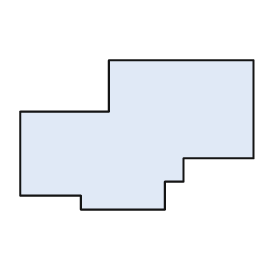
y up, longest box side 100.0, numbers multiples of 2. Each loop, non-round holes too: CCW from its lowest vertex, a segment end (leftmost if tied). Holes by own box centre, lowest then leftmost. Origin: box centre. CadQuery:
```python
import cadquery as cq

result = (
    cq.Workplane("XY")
    .moveTo(-24.0, -32.0)
    .lineTo(12.0, -32.0)
    .lineTo(12.0, -20.0)
    .lineTo(20.0, -20.0)
    .lineTo(20.0, -10.0)
    .lineTo(50.0, -10.0)
    .lineTo(50.0, 32.0)
    .lineTo(-12.0, 32.0)
    .lineTo(-12.0, 10.0)
    .lineTo(-50.0, 10.0)
    .lineTo(-50.0, -26.0)
    .lineTo(-24.0, -26.0)
    .close()
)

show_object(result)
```